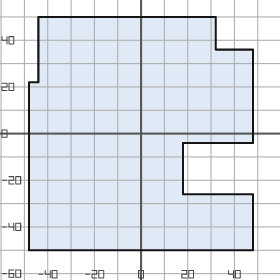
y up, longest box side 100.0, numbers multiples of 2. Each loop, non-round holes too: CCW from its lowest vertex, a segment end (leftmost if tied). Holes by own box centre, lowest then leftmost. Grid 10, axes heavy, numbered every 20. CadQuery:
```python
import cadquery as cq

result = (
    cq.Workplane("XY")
    .moveTo(-48.0, -50.0)
    .lineTo(48.0, -50.0)
    .lineTo(48.0, -26.0)
    .lineTo(18.0, -26.0)
    .lineTo(18.0, -4.0)
    .lineTo(48.0, -4.0)
    .lineTo(48.0, 36.0)
    .lineTo(32.0, 36.0)
    .lineTo(32.0, 50.0)
    .lineTo(-44.0, 50.0)
    .lineTo(-44.0, 22.0)
    .lineTo(-48.0, 22.0)
    .close()
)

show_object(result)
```